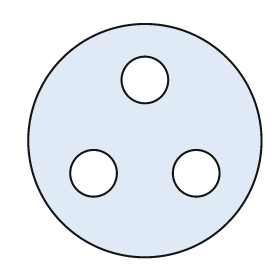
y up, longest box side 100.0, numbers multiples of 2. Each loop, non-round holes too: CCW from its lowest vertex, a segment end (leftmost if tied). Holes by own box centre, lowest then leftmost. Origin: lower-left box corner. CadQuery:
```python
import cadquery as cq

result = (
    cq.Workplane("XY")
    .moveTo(50.0, 50.0)
    .circle(50.0)
    .moveTo(28.0, 36.0)
    .circle(10.0)
    .moveTo(72.0, 36.0)
    .circle(10.0)
    .moveTo(50.0, 76.0)
    .circle(10.0)
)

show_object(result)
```